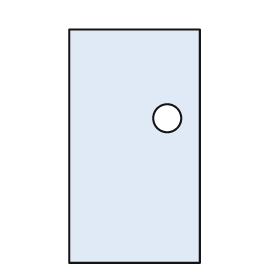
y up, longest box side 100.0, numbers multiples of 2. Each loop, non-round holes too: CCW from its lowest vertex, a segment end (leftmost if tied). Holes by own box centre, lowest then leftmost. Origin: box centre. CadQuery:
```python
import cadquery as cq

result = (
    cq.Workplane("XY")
    .moveTo(-28.0, -50.0)
    .lineTo(28.0, -50.0)
    .lineTo(28.0, 50.0)
    .lineTo(-28.0, 50.0)
    .close()
    .moveTo(14.0, 12.0)
    .circle(6.0)
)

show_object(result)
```